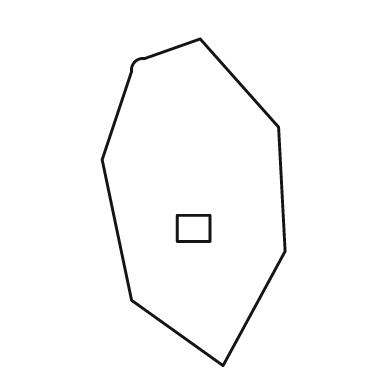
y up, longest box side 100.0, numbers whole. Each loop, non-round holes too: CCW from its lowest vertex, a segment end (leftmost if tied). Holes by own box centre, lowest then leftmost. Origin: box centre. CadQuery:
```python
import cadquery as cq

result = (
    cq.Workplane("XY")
    .moveTo(9.0, -50.0)
    .lineTo(28.0, -15.0)
    .lineTo(26.0, 23.0)
    .lineTo(2.0, 50.0)
    .lineTo(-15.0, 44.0)
    .threePointArc((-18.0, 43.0), (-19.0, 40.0))
    .lineTo(-28.0, 13.0)
    .lineTo(-19.0, -30.0)
    .close()
    .moveTo(-5.0, -12.0)
    .lineTo(5.0, -12.0)
    .lineTo(5.0, -4.0)
    .lineTo(-5.0, -4.0)
    .close()
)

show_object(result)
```